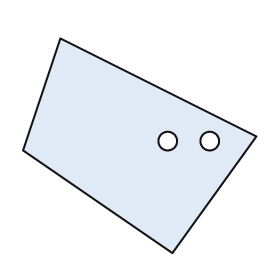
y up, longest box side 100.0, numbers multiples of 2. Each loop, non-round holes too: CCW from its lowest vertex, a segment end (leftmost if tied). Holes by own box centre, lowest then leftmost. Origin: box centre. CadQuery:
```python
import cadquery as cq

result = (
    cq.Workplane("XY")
    .moveTo(14.0, -46.0)
    .lineTo(50.0, 4.0)
    .lineTo(-34.0, 46.0)
    .lineTo(-50.0, -2.0)
    .close()
    .moveTo(12.0, 2.0)
    .circle(4.0)
    .moveTo(30.0, 2.0)
    .circle(4.0)
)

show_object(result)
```